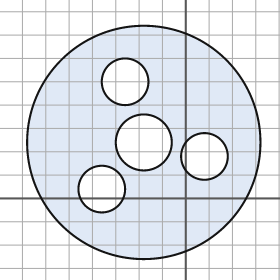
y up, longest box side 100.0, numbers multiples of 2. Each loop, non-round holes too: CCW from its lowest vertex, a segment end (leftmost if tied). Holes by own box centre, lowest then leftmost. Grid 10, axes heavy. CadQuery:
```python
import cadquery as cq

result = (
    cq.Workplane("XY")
    .moveTo(-18.0, 24.0)
    .circle(50.0)
    .moveTo(-36.0, 4.0)
    .circle(10.0)
    .moveTo(8.0, 18.0)
    .circle(10.0)
    .moveTo(-18.0, 24.0)
    .circle(12.0)
    .moveTo(-26.0, 50.0)
    .circle(10.0)
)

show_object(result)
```